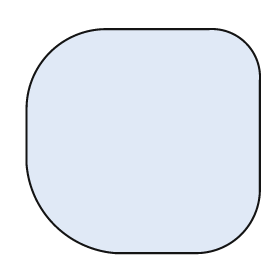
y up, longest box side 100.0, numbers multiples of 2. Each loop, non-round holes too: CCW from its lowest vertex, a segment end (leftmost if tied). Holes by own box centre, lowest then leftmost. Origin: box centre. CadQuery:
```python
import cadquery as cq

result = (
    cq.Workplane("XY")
    .moveTo(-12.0, -48.0)
    .lineTo(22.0, -48.0)
    .threePointArc((42.0, -40.0), (50.0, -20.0))
    .lineTo(50.0, 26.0)
    .threePointArc((44.0, 42.0), (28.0, 48.0))
    .lineTo(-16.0, 48.0)
    .threePointArc((-40.0, 38.0), (-50.0, 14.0))
    .lineTo(-50.0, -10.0)
    .threePointArc((-38.0, -36.0), (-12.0, -48.0))
    .close()
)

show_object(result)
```